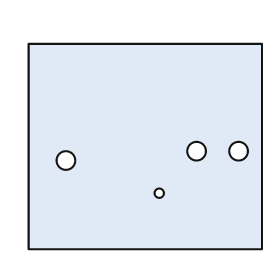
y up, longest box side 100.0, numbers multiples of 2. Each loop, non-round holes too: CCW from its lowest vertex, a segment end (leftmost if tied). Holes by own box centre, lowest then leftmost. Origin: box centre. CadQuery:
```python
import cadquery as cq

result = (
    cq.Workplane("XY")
    .moveTo(-50.0, -44.0)
    .lineTo(50.0, -44.0)
    .lineTo(50.0, 44.0)
    .lineTo(-50.0, 44.0)
    .close()
    .moveTo(6.0, -20.0)
    .circle(2.0)
    .moveTo(-34.0, -6.0)
    .circle(4.0)
    .moveTo(22.0, -2.0)
    .circle(4.0)
    .moveTo(40.0, -2.0)
    .circle(4.0)
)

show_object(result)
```